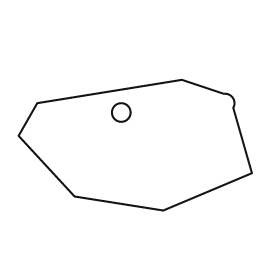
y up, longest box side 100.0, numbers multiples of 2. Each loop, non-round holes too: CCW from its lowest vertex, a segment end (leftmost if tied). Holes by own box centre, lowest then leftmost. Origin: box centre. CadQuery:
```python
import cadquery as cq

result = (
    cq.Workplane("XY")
    .moveTo(12.0, -28.0)
    .lineTo(50.0, -12.0)
    .lineTo(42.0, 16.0)
    .threePointArc((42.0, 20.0), (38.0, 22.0))
    .lineTo(20.0, 28.0)
    .lineTo(-42.0, 18.0)
    .lineTo(-50.0, 4.0)
    .lineTo(-26.0, -22.0)
    .close()
    .moveTo(-6.0, 14.0)
    .circle(4.0)
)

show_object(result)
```